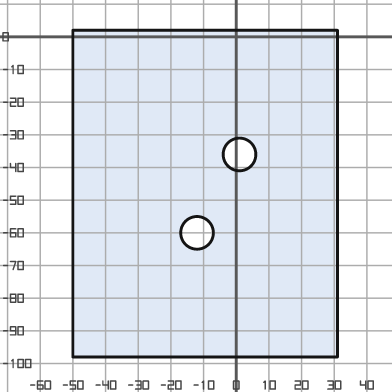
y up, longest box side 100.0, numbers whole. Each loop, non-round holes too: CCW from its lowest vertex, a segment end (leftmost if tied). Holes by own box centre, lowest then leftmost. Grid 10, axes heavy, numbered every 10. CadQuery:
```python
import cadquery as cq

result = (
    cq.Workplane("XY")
    .moveTo(-50.0, -98.0)
    .lineTo(31.0, -98.0)
    .lineTo(31.0, 2.0)
    .lineTo(-50.0, 2.0)
    .close()
    .moveTo(-12.0, -60.0)
    .circle(5.0)
    .moveTo(1.0, -36.0)
    .circle(5.0)
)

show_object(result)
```